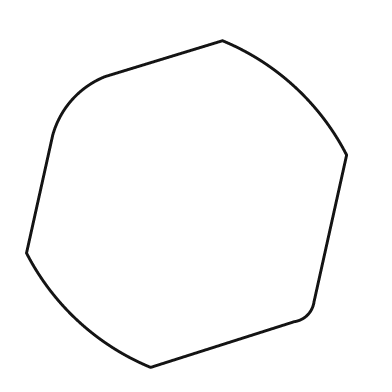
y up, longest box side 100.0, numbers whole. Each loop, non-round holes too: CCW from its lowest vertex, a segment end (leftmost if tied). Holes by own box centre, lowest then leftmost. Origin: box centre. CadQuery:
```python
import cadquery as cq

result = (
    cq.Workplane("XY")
    .moveTo(-11.0, -50.0)
    .lineTo(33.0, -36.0)
    .threePointArc((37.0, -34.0), (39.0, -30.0))
    .lineTo(49.0, 15.0)
    .threePointArc((33.0, 36.0), (11.0, 50.0))
    .lineTo(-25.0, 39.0)
    .threePointArc((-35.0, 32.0), (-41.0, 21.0))
    .lineTo(-49.0, -15.0)
    .threePointArc((-33.0, -36.0), (-11.0, -50.0))
    .close()
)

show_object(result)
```